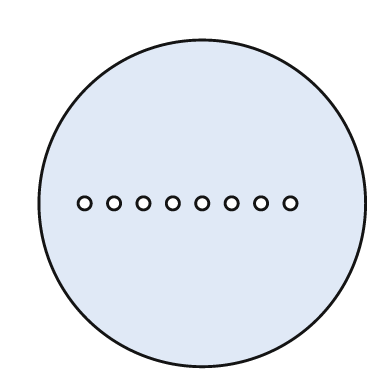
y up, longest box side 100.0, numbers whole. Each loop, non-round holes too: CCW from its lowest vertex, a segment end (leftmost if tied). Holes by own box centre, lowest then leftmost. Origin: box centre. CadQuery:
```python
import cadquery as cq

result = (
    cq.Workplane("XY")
    .moveTo(0.0, 0.0)
    .circle(50.0)
    .moveTo(-36.0, 0.0)
    .circle(2.0)
    .moveTo(-27.0, 0.0)
    .circle(2.0)
    .moveTo(-18.0, 0.0)
    .circle(2.0)
    .moveTo(-9.0, 0.0)
    .circle(2.0)
    .moveTo(0.0, 0.0)
    .circle(2.0)
    .moveTo(9.0, 0.0)
    .circle(2.0)
    .moveTo(18.0, 0.0)
    .circle(2.0)
    .moveTo(27.0, 0.0)
    .circle(2.0)
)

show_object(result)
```